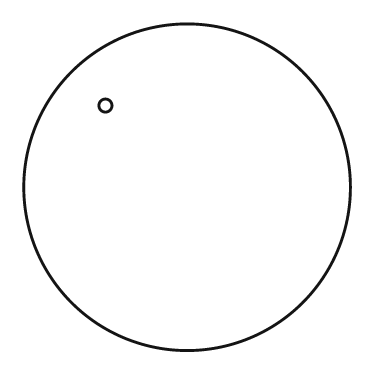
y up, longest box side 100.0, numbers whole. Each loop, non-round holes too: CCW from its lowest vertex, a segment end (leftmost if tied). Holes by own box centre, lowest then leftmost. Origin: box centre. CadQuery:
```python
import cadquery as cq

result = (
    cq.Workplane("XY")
    .moveTo(0.0, 0.0)
    .circle(50.0)
    .moveTo(-25.0, 25.0)
    .circle(2.0)
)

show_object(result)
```